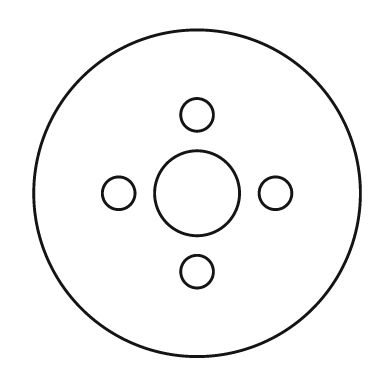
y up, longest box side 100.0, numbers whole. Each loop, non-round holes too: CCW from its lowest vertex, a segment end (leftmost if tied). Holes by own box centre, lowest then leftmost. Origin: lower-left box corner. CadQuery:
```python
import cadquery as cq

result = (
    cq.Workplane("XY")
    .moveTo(50.0, 50.0)
    .circle(50.0)
    .moveTo(50.0, 26.0)
    .circle(5.0)
    .moveTo(26.0, 50.0)
    .circle(5.0)
    .moveTo(50.0, 50.0)
    .circle(13.0)
    .moveTo(74.0, 50.0)
    .circle(5.0)
    .moveTo(50.0, 74.0)
    .circle(5.0)
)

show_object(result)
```